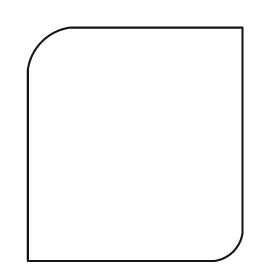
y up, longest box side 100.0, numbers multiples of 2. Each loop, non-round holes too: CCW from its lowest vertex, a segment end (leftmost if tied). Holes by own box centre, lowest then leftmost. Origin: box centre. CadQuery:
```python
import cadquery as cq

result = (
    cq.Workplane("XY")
    .moveTo(-46.0, -50.0)
    .lineTo(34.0, -50.0)
    .threePointArc((42.0, -46.0), (46.0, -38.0))
    .lineTo(46.0, 50.0)
    .lineTo(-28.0, 50.0)
    .threePointArc((-40.0, 44.0), (-46.0, 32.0))
    .close()
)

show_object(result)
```